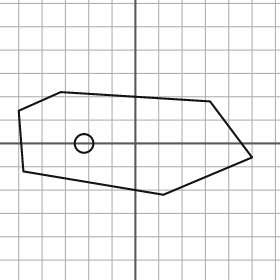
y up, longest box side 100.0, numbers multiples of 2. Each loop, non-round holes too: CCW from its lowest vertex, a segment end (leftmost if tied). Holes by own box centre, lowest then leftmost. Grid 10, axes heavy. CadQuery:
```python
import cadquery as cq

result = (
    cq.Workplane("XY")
    .moveTo(12.0, -22.0)
    .lineTo(50.0, -6.0)
    .lineTo(32.0, 18.0)
    .lineTo(-32.0, 22.0)
    .lineTo(-50.0, 14.0)
    .lineTo(-48.0, -12.0)
    .close()
    .moveTo(-22.0, 0.0)
    .circle(4.0)
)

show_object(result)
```